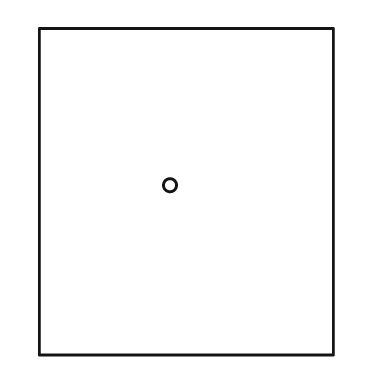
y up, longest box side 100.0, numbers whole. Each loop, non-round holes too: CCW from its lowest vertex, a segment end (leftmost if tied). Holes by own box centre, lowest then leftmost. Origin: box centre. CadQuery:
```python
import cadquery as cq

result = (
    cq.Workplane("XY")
    .moveTo(-45.0, -50.0)
    .lineTo(45.0, -50.0)
    .lineTo(45.0, 50.0)
    .lineTo(-45.0, 50.0)
    .close()
    .moveTo(-5.0, 2.0)
    .circle(2.0)
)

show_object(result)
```